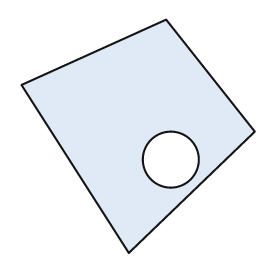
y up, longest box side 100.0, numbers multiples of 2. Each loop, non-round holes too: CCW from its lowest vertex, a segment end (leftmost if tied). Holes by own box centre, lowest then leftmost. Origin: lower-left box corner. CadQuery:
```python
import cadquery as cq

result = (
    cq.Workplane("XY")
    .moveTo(46.0, 0.0)
    .lineTo(100.0, 52.0)
    .lineTo(62.0, 100.0)
    .lineTo(0.0, 72.0)
    .close()
    .moveTo(64.0, 40.0)
    .circle(12.0)
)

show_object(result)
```